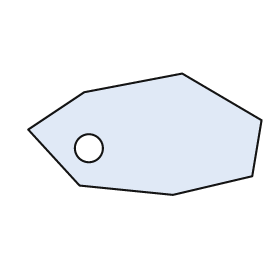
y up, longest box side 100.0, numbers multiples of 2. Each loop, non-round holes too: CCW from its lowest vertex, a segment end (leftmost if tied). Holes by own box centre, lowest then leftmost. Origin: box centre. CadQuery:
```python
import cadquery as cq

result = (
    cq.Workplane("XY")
    .moveTo(12.0, -26.0)
    .lineTo(46.0, -18.0)
    .lineTo(50.0, 6.0)
    .lineTo(16.0, 26.0)
    .lineTo(-26.0, 18.0)
    .lineTo(-50.0, 2.0)
    .lineTo(-28.0, -22.0)
    .close()
    .moveTo(-24.0, -6.0)
    .circle(6.0)
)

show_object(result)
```